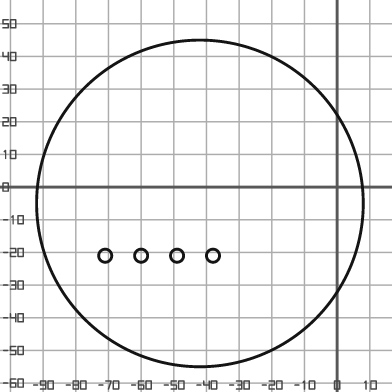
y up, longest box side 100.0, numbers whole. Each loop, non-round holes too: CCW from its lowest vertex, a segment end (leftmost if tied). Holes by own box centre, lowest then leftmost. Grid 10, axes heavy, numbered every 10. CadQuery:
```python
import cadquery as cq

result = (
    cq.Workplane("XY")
    .moveTo(-42.0, -5.0)
    .circle(50.0)
    .moveTo(-71.0, -21.0)
    .circle(2.0)
    .moveTo(-60.0, -21.0)
    .circle(2.0)
    .moveTo(-49.0, -21.0)
    .circle(2.0)
    .moveTo(-38.0, -21.0)
    .circle(2.0)
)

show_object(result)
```